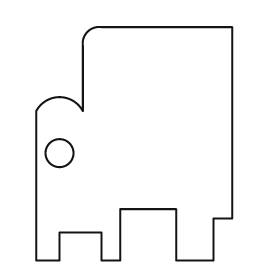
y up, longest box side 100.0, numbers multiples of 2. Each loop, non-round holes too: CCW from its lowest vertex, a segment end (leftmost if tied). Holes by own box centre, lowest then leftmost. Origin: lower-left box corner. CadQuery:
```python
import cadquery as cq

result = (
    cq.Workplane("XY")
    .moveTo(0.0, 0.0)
    .lineTo(10.0, 0.0)
    .lineTo(10.0, 12.0)
    .lineTo(28.0, 12.0)
    .lineTo(28.0, 0.0)
    .lineTo(36.0, 0.0)
    .lineTo(36.0, 22.0)
    .lineTo(60.0, 22.0)
    .lineTo(60.0, 0.0)
    .lineTo(76.0, 0.0)
    .lineTo(76.0, 18.0)
    .lineTo(84.0, 18.0)
    .lineTo(84.0, 100.0)
    .lineTo(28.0, 100.0)
    .threePointArc((22.0, 98.0), (20.0, 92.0))
    .lineTo(20.0, 64.0)
    .threePointArc((10.0, 70.0), (0.0, 64.0))
    .close()
    .moveTo(10.0, 46.0)
    .circle(6.0)
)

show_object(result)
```